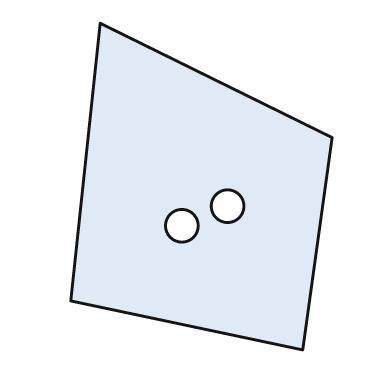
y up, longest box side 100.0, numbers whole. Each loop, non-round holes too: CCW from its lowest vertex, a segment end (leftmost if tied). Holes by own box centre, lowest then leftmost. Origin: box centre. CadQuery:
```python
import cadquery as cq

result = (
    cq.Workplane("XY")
    .moveTo(31.0, -50.0)
    .lineTo(40.0, 15.0)
    .lineTo(-31.0, 50.0)
    .lineTo(-40.0, -35.0)
    .close()
    .moveTo(-6.0, -12.0)
    .circle(5.0)
    .moveTo(8.0, -6.0)
    .circle(5.0)
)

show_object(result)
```